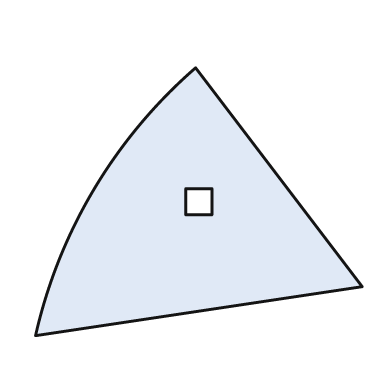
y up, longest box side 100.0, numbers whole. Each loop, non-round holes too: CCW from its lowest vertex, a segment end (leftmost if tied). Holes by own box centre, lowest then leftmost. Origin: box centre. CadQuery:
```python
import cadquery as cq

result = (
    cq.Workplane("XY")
    .moveTo(-50.0, -41.0)
    .lineTo(50.0, -26.0)
    .lineTo(-1.0, 41.0)
    .threePointArc((-32.0, 4.0), (-50.0, -41.0))
    .close()
    .moveTo(-4.0, -4.0)
    .lineTo(4.0, -4.0)
    .lineTo(4.0, 4.0)
    .lineTo(-4.0, 4.0)
    .close()
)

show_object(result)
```